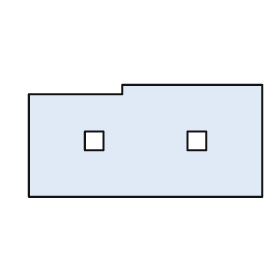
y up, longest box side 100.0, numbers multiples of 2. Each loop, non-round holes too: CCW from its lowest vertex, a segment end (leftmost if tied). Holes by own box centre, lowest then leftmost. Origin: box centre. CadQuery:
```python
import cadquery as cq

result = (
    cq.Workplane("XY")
    .moveTo(-50.0, -24.0)
    .lineTo(50.0, -24.0)
    .lineTo(50.0, 24.0)
    .lineTo(-10.0, 24.0)
    .lineTo(-10.0, 20.0)
    .lineTo(-50.0, 20.0)
    .close()
    .moveTo(-26.0, -4.0)
    .lineTo(-18.0, -4.0)
    .lineTo(-18.0, 4.0)
    .lineTo(-26.0, 4.0)
    .close()
    .moveTo(18.0, -4.0)
    .lineTo(26.0, -4.0)
    .lineTo(26.0, 4.0)
    .lineTo(18.0, 4.0)
    .close()
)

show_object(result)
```